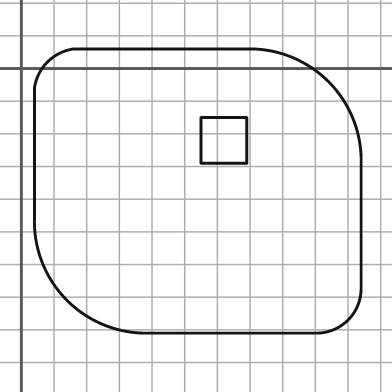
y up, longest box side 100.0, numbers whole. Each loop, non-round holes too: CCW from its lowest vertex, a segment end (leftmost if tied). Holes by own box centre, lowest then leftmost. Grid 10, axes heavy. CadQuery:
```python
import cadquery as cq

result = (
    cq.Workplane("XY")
    .moveTo(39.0, -81.0)
    .lineTo(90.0, -81.0)
    .threePointArc((100.0, -77.0), (104.0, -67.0))
    .lineTo(104.0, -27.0)
    .threePointArc((94.0, -4.0), (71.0, 6.0))
    .lineTo(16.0, 6.0)
    .threePointArc((8.0, 2.0), (4.0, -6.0))
    .lineTo(4.0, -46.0)
    .threePointArc((14.0, -71.0), (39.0, -81.0))
    .close()
    .moveTo(55.0, -29.0)
    .lineTo(69.0, -29.0)
    .lineTo(69.0, -15.0)
    .lineTo(55.0, -15.0)
    .close()
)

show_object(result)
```